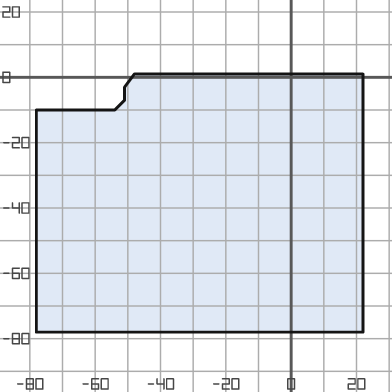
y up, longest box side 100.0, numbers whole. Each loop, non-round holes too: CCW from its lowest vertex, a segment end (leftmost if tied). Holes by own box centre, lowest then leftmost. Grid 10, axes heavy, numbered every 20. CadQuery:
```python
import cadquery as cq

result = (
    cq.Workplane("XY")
    .moveTo(-78.0, -78.0)
    .lineTo(22.0, -78.0)
    .lineTo(22.0, 1.0)
    .lineTo(-48.0, 1.0)
    .lineTo(-51.0, -3.0)
    .lineTo(-51.0, -7.0)
    .lineTo(-54.0, -10.0)
    .lineTo(-78.0, -10.0)
    .close()
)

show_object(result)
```